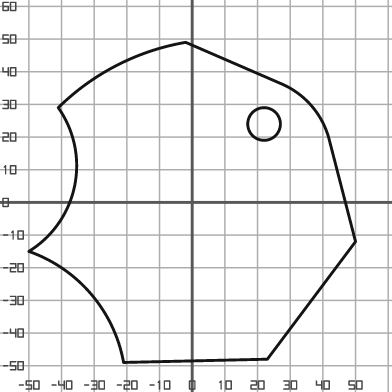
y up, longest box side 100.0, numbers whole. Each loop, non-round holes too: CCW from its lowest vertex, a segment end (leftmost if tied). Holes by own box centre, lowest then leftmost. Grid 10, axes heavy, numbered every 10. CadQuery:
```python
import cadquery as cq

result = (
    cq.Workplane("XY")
    .moveTo(-21.0, -49.0)
    .lineTo(23.0, -48.0)
    .lineTo(50.0, -12.0)
    .lineTo(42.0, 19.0)
    .threePointArc((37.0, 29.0), (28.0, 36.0))
    .lineTo(-2.0, 49.0)
    .threePointArc((-23.0, 42.0), (-41.0, 29.0))
    .threePointArc((-36.0, 5.0), (-50.0, -15.0))
    .threePointArc((-31.0, -28.0), (-21.0, -49.0))
    .close()
    .moveTo(22.0, 24.0)
    .circle(5.0)
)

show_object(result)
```